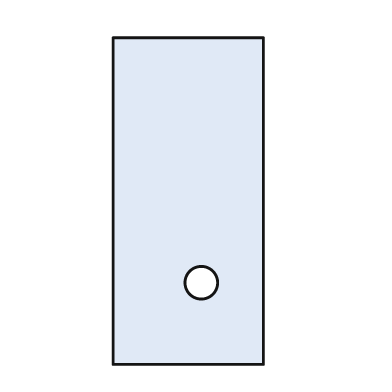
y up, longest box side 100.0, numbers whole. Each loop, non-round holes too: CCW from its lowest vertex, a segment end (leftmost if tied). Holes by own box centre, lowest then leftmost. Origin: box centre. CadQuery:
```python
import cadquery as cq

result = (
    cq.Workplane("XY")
    .moveTo(-23.0, -50.0)
    .lineTo(23.0, -50.0)
    .lineTo(23.0, 50.0)
    .lineTo(-23.0, 50.0)
    .close()
    .moveTo(4.0, -25.0)
    .circle(5.0)
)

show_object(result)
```